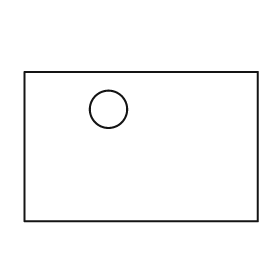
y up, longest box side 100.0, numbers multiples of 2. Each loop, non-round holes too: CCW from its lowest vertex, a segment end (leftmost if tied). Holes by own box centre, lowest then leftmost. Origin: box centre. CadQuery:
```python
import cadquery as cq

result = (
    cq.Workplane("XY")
    .moveTo(-50.0, -32.0)
    .lineTo(50.0, -32.0)
    .lineTo(50.0, 32.0)
    .lineTo(-50.0, 32.0)
    .close()
    .moveTo(-14.0, 16.0)
    .circle(8.0)
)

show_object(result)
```